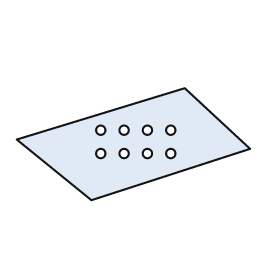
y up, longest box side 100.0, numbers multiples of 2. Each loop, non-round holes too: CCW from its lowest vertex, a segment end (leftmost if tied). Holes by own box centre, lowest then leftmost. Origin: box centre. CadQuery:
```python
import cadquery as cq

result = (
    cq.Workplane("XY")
    .moveTo(-18.0, -24.0)
    .lineTo(50.0, -2.0)
    .lineTo(22.0, 24.0)
    .lineTo(-50.0, 2.0)
    .close()
    .moveTo(-14.0, -4.0)
    .circle(2.0)
    .moveTo(-4.0, -4.0)
    .circle(2.0)
    .moveTo(6.0, -4.0)
    .circle(2.0)
    .moveTo(16.0, -4.0)
    .circle(2.0)
    .moveTo(-14.0, 6.0)
    .circle(2.0)
    .moveTo(-4.0, 6.0)
    .circle(2.0)
    .moveTo(6.0, 6.0)
    .circle(2.0)
    .moveTo(16.0, 6.0)
    .circle(2.0)
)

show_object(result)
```